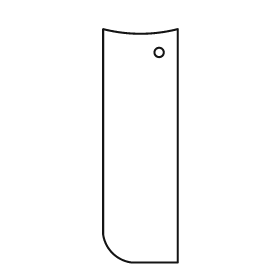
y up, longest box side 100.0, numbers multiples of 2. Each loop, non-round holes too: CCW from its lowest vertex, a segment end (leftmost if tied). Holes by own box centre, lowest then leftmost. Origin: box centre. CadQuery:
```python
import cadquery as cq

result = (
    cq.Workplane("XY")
    .moveTo(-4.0, -50.0)
    .lineTo(16.0, -50.0)
    .lineTo(16.0, 50.0)
    .threePointArc((0.0, 48.0), (-16.0, 50.0))
    .lineTo(-16.0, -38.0)
    .threePointArc((-12.0, -46.0), (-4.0, -50.0))
    .close()
    .moveTo(8.0, 40.0)
    .circle(2.0)
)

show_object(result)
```